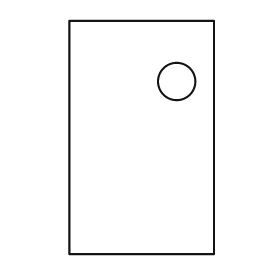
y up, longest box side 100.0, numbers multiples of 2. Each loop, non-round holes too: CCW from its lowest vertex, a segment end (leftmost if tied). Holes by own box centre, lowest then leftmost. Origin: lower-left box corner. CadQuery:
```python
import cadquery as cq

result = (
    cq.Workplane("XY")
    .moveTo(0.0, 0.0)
    .lineTo(62.0, 0.0)
    .lineTo(62.0, 100.0)
    .lineTo(0.0, 100.0)
    .close()
    .moveTo(46.0, 74.0)
    .circle(8.0)
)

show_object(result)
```